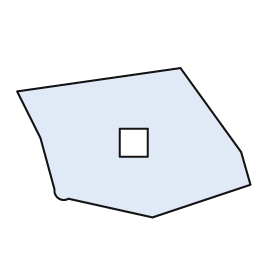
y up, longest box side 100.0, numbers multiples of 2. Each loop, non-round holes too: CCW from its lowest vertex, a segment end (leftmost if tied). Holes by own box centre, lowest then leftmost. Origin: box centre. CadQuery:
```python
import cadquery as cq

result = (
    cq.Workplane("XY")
    .moveTo(8.0, -32.0)
    .lineTo(50.0, -18.0)
    .lineTo(46.0, -4.0)
    .lineTo(20.0, 32.0)
    .lineTo(-50.0, 22.0)
    .lineTo(-40.0, 2.0)
    .lineTo(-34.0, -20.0)
    .threePointArc((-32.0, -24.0), (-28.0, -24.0))
    .close()
    .moveTo(-6.0, -6.0)
    .lineTo(6.0, -6.0)
    .lineTo(6.0, 6.0)
    .lineTo(-6.0, 6.0)
    .close()
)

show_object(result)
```